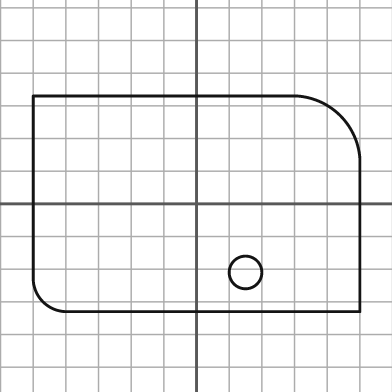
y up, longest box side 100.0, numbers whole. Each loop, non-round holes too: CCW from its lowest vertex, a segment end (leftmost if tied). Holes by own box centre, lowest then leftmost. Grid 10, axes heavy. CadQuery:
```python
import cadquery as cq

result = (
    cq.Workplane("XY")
    .moveTo(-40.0, -33.0)
    .lineTo(50.0, -33.0)
    .lineTo(50.0, 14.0)
    .threePointArc((44.0, 27.0), (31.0, 33.0))
    .lineTo(-50.0, 33.0)
    .lineTo(-50.0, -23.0)
    .threePointArc((-47.0, -30.0), (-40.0, -33.0))
    .close()
    .moveTo(15.0, -21.0)
    .circle(5.0)
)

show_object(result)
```